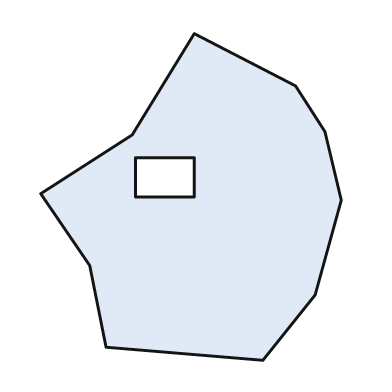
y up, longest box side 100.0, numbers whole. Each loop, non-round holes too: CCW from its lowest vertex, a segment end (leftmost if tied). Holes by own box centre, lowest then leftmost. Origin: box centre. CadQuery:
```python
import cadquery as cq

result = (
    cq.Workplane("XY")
    .moveTo(22.0, -50.0)
    .lineTo(38.0, -30.0)
    .lineTo(46.0, -1.0)
    .lineTo(41.0, 20.0)
    .lineTo(32.0, 34.0)
    .lineTo(1.0, 50.0)
    .lineTo(-18.0, 19.0)
    .lineTo(-46.0, 1.0)
    .lineTo(-31.0, -21.0)
    .lineTo(-26.0, -46.0)
    .close()
    .moveTo(-17.0, 0.0)
    .lineTo(1.0, 0.0)
    .lineTo(1.0, 12.0)
    .lineTo(-17.0, 12.0)
    .close()
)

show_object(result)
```